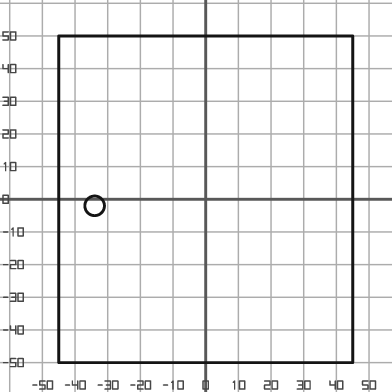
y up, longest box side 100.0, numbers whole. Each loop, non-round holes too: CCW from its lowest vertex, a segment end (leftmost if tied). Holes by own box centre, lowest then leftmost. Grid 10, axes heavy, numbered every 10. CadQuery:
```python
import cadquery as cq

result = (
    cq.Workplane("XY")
    .moveTo(-45.0, -50.0)
    .lineTo(45.0, -50.0)
    .lineTo(45.0, 50.0)
    .lineTo(-45.0, 50.0)
    .close()
    .moveTo(-34.0, -2.0)
    .circle(3.0)
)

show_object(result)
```